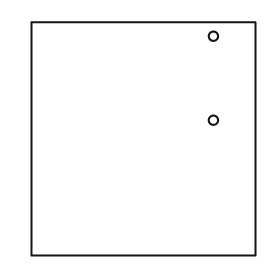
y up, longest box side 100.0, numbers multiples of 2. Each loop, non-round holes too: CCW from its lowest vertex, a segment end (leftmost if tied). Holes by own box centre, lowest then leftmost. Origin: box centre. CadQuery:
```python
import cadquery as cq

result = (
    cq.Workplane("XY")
    .moveTo(-48.0, -50.0)
    .lineTo(48.0, -50.0)
    .lineTo(48.0, 50.0)
    .lineTo(-48.0, 50.0)
    .close()
    .moveTo(30.0, 8.0)
    .circle(2.0)
    .moveTo(30.0, 44.0)
    .circle(2.0)
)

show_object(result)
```